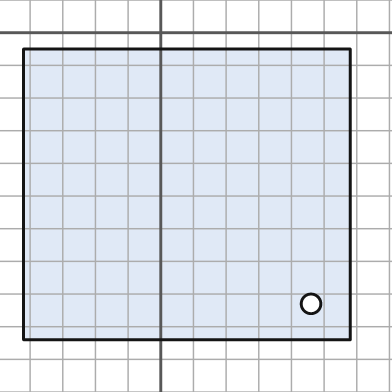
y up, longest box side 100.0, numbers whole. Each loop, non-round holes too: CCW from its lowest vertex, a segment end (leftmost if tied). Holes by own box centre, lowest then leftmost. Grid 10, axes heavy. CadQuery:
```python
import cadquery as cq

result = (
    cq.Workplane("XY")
    .moveTo(-42.0, -94.0)
    .lineTo(58.0, -94.0)
    .lineTo(58.0, -5.0)
    .lineTo(-42.0, -5.0)
    .close()
    .moveTo(46.0, -83.0)
    .circle(3.0)
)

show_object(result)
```